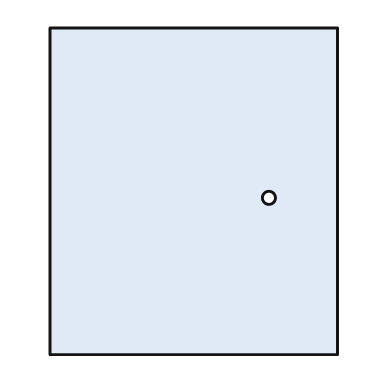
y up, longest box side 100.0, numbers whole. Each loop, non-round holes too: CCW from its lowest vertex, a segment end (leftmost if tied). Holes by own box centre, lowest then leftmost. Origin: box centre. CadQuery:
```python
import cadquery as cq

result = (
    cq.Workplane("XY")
    .moveTo(-44.0, -50.0)
    .lineTo(44.0, -50.0)
    .lineTo(44.0, 50.0)
    .lineTo(-44.0, 50.0)
    .close()
    .moveTo(23.0, -2.0)
    .circle(2.0)
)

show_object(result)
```